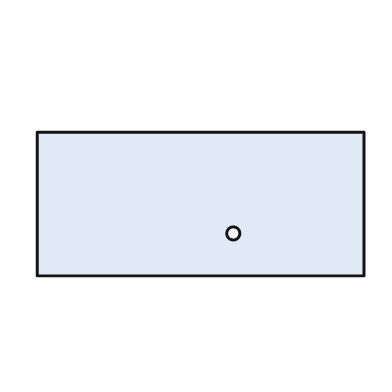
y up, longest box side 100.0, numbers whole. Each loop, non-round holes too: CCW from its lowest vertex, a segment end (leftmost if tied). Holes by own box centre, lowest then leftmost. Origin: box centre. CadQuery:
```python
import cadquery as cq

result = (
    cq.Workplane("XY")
    .moveTo(-50.0, -22.0)
    .lineTo(50.0, -22.0)
    .lineTo(50.0, 22.0)
    .lineTo(-50.0, 22.0)
    .close()
    .moveTo(10.0, -9.0)
    .circle(2.0)
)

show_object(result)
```